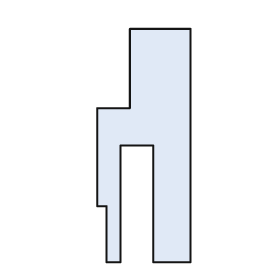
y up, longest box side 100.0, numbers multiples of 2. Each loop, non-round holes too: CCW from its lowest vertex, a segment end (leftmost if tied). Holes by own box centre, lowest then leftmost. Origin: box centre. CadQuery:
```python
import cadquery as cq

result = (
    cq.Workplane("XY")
    .moveTo(-16.0, -50.0)
    .lineTo(-10.0, -50.0)
    .lineTo(-10.0, 0.0)
    .lineTo(4.0, 0.0)
    .lineTo(4.0, -50.0)
    .lineTo(20.0, -50.0)
    .lineTo(20.0, 50.0)
    .lineTo(-6.0, 50.0)
    .lineTo(-6.0, 16.0)
    .lineTo(-20.0, 16.0)
    .lineTo(-20.0, -26.0)
    .lineTo(-16.0, -26.0)
    .close()
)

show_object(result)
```